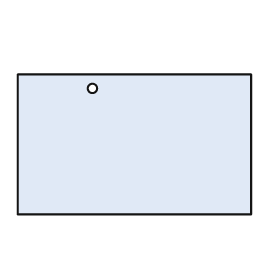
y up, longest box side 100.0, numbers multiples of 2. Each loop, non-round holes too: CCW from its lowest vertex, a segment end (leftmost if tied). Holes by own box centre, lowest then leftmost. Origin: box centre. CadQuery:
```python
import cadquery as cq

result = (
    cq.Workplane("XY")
    .moveTo(-50.0, -30.0)
    .lineTo(50.0, -30.0)
    .lineTo(50.0, 30.0)
    .lineTo(-50.0, 30.0)
    .close()
    .moveTo(-18.0, 24.0)
    .circle(2.0)
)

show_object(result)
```